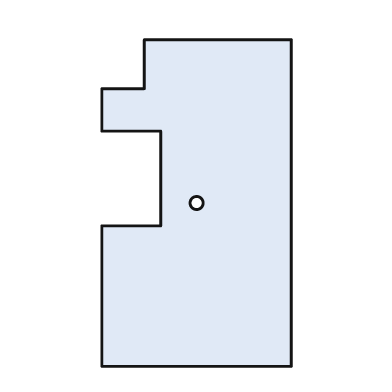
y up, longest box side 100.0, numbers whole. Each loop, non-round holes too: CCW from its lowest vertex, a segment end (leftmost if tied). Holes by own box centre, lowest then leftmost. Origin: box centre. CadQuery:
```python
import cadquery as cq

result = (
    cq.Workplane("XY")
    .moveTo(-29.0, -50.0)
    .lineTo(29.0, -50.0)
    .lineTo(29.0, 50.0)
    .lineTo(-16.0, 50.0)
    .lineTo(-16.0, 35.0)
    .lineTo(-29.0, 35.0)
    .lineTo(-29.0, 22.0)
    .lineTo(-11.0, 22.0)
    .lineTo(-11.0, -7.0)
    .lineTo(-29.0, -7.0)
    .close()
    .moveTo(0.0, 0.0)
    .circle(2.0)
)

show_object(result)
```